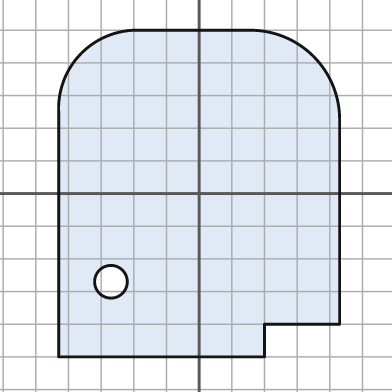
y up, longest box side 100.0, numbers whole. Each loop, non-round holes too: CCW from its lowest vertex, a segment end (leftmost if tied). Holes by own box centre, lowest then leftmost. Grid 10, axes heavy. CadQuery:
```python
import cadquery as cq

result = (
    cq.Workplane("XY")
    .moveTo(-43.0, -50.0)
    .lineTo(20.0, -50.0)
    .lineTo(20.0, -40.0)
    .lineTo(43.0, -40.0)
    .lineTo(43.0, 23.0)
    .threePointArc((35.0, 42.0), (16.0, 50.0))
    .lineTo(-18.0, 50.0)
    .threePointArc((-36.0, 43.0), (-43.0, 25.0))
    .close()
    .moveTo(-27.0, -27.0)
    .circle(5.0)
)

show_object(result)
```